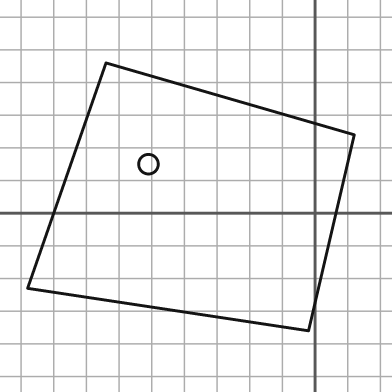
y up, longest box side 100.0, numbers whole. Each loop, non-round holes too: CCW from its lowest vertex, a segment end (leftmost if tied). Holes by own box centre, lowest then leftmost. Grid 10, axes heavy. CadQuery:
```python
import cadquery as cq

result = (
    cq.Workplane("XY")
    .moveTo(-2.0, -36.0)
    .lineTo(12.0, 24.0)
    .lineTo(-64.0, 46.0)
    .lineTo(-88.0, -23.0)
    .close()
    .moveTo(-51.0, 15.0)
    .circle(3.0)
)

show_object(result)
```